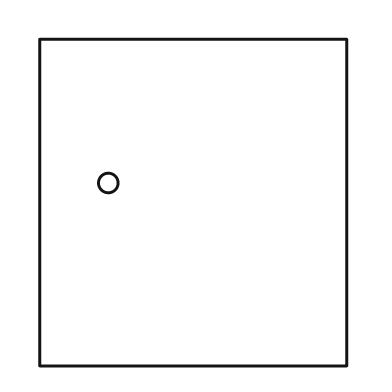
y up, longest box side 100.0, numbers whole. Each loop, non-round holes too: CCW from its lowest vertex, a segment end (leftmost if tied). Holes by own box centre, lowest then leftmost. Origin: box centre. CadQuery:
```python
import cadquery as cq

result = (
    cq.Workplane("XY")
    .moveTo(-47.0, -50.0)
    .lineTo(47.0, -50.0)
    .lineTo(47.0, 50.0)
    .lineTo(-47.0, 50.0)
    .close()
    .moveTo(-26.0, 6.0)
    .circle(3.0)
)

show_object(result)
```